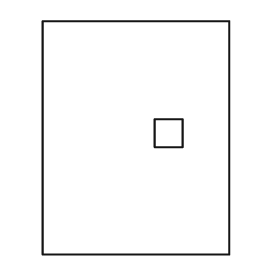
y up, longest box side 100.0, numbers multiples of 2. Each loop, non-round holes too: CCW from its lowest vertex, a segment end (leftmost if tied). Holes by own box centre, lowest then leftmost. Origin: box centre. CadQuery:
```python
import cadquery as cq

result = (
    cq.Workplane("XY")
    .moveTo(-40.0, -50.0)
    .lineTo(40.0, -50.0)
    .lineTo(40.0, 50.0)
    .lineTo(-40.0, 50.0)
    .close()
    .moveTo(8.0, -4.0)
    .lineTo(20.0, -4.0)
    .lineTo(20.0, 8.0)
    .lineTo(8.0, 8.0)
    .close()
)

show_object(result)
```